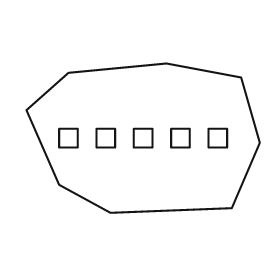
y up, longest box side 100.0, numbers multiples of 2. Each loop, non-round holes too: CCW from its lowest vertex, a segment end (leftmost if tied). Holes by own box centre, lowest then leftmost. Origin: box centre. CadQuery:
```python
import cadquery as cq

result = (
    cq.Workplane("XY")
    .moveTo(-14.0, -32.0)
    .lineTo(38.0, -30.0)
    .lineTo(50.0, -2.0)
    .lineTo(42.0, 26.0)
    .lineTo(10.0, 32.0)
    .lineTo(-32.0, 28.0)
    .lineTo(-50.0, 12.0)
    .lineTo(-36.0, -20.0)
    .close()
    .moveTo(-36.0, -4.0)
    .lineTo(-28.0, -4.0)
    .lineTo(-28.0, 4.0)
    .lineTo(-36.0, 4.0)
    .close()
    .moveTo(-20.0, -4.0)
    .lineTo(-12.0, -4.0)
    .lineTo(-12.0, 4.0)
    .lineTo(-20.0, 4.0)
    .close()
    .moveTo(-4.0, -4.0)
    .lineTo(4.0, -4.0)
    .lineTo(4.0, 4.0)
    .lineTo(-4.0, 4.0)
    .close()
    .moveTo(12.0, -4.0)
    .lineTo(20.0, -4.0)
    .lineTo(20.0, 4.0)
    .lineTo(12.0, 4.0)
    .close()
    .moveTo(28.0, -4.0)
    .lineTo(36.0, -4.0)
    .lineTo(36.0, 4.0)
    .lineTo(28.0, 4.0)
    .close()
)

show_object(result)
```